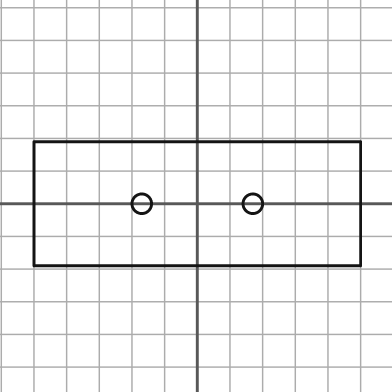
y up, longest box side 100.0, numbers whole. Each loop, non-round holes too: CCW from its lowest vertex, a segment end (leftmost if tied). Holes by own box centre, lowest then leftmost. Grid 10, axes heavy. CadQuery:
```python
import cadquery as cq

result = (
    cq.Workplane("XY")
    .moveTo(-50.0, -19.0)
    .lineTo(50.0, -19.0)
    .lineTo(50.0, 19.0)
    .lineTo(-50.0, 19.0)
    .close()
    .moveTo(-17.0, 0.0)
    .circle(3.0)
    .moveTo(17.0, 0.0)
    .circle(3.0)
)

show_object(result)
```